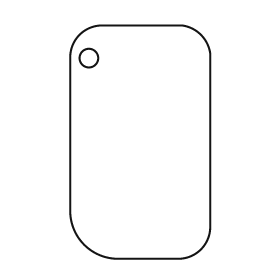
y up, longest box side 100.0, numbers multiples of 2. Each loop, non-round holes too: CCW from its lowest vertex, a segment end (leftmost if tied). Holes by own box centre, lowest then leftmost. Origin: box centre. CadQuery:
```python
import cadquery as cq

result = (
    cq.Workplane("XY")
    .moveTo(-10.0, -50.0)
    .lineTo(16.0, -50.0)
    .threePointArc((26.0, -46.0), (30.0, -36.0))
    .lineTo(30.0, 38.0)
    .threePointArc((26.0, 46.0), (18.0, 50.0))
    .lineTo(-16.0, 50.0)
    .threePointArc((-26.0, 46.0), (-30.0, 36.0))
    .lineTo(-30.0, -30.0)
    .threePointArc((-24.0, -44.0), (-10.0, -50.0))
    .close()
    .moveTo(-22.0, 36.0)
    .circle(4.0)
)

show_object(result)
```